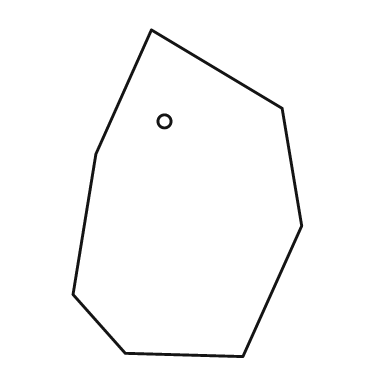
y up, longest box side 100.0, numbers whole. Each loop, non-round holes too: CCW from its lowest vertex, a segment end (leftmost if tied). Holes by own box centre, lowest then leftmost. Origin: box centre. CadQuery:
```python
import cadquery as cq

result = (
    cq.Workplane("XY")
    .moveTo(17.0, -50.0)
    .lineTo(35.0, -10.0)
    .lineTo(29.0, 26.0)
    .lineTo(-11.0, 50.0)
    .lineTo(-28.0, 12.0)
    .lineTo(-35.0, -31.0)
    .lineTo(-19.0, -49.0)
    .close()
    .moveTo(-7.0, 22.0)
    .circle(2.0)
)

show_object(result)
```